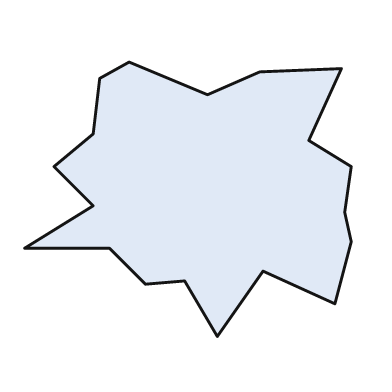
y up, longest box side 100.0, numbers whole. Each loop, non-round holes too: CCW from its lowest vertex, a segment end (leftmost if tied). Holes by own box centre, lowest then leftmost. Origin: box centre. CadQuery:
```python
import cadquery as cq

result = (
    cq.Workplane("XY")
    .moveTo(9.0, -42.0)
    .lineTo(23.0, -22.0)
    .lineTo(45.0, -32.0)
    .lineTo(50.0, -13.0)
    .lineTo(48.0, -4.0)
    .lineTo(50.0, 10.0)
    .lineTo(37.0, 18.0)
    .lineTo(47.0, 40.0)
    .lineTo(22.0, 39.0)
    .lineTo(6.0, 32.0)
    .lineTo(-18.0, 42.0)
    .lineTo(-27.0, 37.0)
    .lineTo(-29.0, 20.0)
    .lineTo(-41.0, 10.0)
    .lineTo(-29.0, -2.0)
    .lineTo(-50.0, -15.0)
    .lineTo(-24.0, -15.0)
    .lineTo(-13.0, -26.0)
    .lineTo(-1.0, -25.0)
    .close()
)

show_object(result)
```